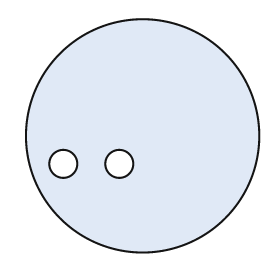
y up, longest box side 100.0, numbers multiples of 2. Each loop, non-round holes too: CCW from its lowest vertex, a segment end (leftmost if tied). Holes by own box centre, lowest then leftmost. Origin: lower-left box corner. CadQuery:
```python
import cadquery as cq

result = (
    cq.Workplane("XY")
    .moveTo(50.0, 50.0)
    .circle(50.0)
    .moveTo(16.0, 38.0)
    .circle(6.0)
    .moveTo(40.0, 38.0)
    .circle(6.0)
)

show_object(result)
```